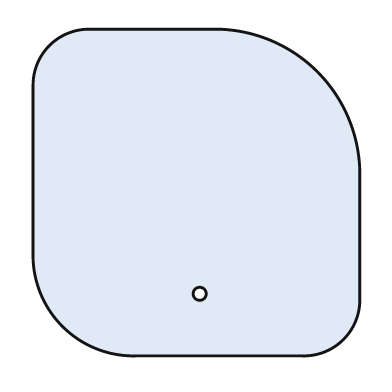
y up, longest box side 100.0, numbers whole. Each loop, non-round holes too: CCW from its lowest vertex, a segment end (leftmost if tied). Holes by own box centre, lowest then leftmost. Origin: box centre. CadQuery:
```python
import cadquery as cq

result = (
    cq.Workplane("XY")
    .moveTo(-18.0, -50.0)
    .lineTo(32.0, -50.0)
    .threePointArc((45.0, -45.0), (50.0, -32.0))
    .lineTo(50.0, 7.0)
    .threePointArc((37.0, 37.0), (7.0, 50.0))
    .lineTo(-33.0, 50.0)
    .threePointArc((-45.0, 45.0), (-50.0, 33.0))
    .lineTo(-50.0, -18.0)
    .threePointArc((-41.0, -41.0), (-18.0, -50.0))
    .close()
    .moveTo(1.0, -31.0)
    .circle(2.0)
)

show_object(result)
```